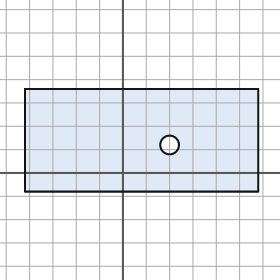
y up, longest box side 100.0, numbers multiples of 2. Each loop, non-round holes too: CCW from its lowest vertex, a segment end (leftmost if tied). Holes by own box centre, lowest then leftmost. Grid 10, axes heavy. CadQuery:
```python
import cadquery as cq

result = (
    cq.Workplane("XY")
    .moveTo(-42.0, -8.0)
    .lineTo(58.0, -8.0)
    .lineTo(58.0, 36.0)
    .lineTo(-42.0, 36.0)
    .close()
    .moveTo(20.0, 12.0)
    .circle(4.0)
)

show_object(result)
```